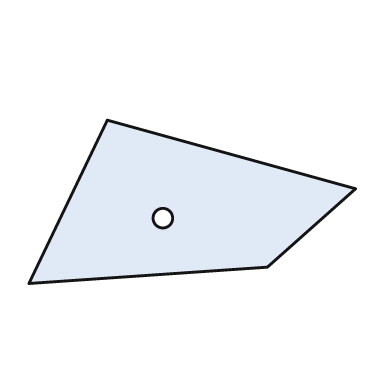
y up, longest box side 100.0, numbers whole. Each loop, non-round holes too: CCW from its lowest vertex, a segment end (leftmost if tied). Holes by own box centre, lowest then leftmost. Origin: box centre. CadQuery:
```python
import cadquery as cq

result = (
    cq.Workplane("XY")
    .moveTo(-50.0, -25.0)
    .lineTo(23.0, -20.0)
    .lineTo(50.0, 4.0)
    .lineTo(-26.0, 25.0)
    .close()
    .moveTo(-9.0, -5.0)
    .circle(3.0)
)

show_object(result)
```